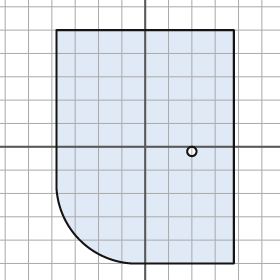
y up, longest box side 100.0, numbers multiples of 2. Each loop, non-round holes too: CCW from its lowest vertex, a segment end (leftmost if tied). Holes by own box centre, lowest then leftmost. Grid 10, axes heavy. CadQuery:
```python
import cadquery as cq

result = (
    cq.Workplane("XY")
    .moveTo(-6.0, -50.0)
    .lineTo(38.0, -50.0)
    .lineTo(38.0, 50.0)
    .lineTo(-38.0, 50.0)
    .lineTo(-38.0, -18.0)
    .threePointArc((-28.0, -40.0), (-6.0, -50.0))
    .close()
    .moveTo(20.0, -2.0)
    .circle(2.0)
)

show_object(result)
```